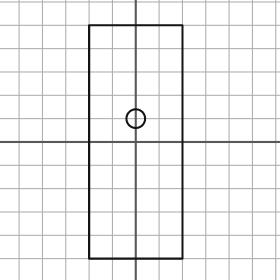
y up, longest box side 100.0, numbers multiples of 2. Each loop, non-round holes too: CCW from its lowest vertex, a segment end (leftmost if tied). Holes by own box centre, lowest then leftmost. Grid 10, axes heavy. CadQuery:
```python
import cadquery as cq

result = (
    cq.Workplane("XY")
    .moveTo(-20.0, -50.0)
    .lineTo(20.0, -50.0)
    .lineTo(20.0, 50.0)
    .lineTo(-20.0, 50.0)
    .close()
    .moveTo(0.0, 10.0)
    .circle(4.0)
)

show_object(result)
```